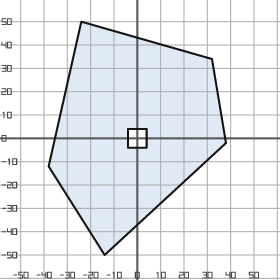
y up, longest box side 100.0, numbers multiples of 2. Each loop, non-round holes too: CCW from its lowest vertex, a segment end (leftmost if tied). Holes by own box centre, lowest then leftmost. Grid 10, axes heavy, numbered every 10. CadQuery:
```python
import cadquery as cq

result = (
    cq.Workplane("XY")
    .moveTo(-14.0, -50.0)
    .lineTo(38.0, -2.0)
    .lineTo(32.0, 34.0)
    .lineTo(-24.0, 50.0)
    .lineTo(-38.0, -12.0)
    .close()
    .moveTo(-4.0, -4.0)
    .lineTo(4.0, -4.0)
    .lineTo(4.0, 4.0)
    .lineTo(-4.0, 4.0)
    .close()
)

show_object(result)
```